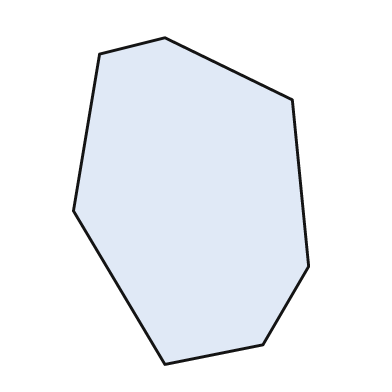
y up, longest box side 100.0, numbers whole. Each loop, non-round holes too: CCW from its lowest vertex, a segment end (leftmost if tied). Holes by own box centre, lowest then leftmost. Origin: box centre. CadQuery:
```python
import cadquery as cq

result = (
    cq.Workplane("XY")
    .moveTo(-8.0, -50.0)
    .lineTo(22.0, -44.0)
    .lineTo(36.0, -20.0)
    .lineTo(31.0, 31.0)
    .lineTo(-8.0, 50.0)
    .lineTo(-28.0, 45.0)
    .lineTo(-36.0, -3.0)
    .close()
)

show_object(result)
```